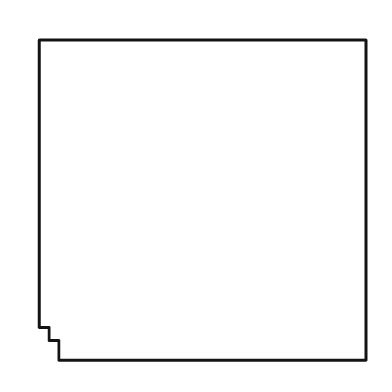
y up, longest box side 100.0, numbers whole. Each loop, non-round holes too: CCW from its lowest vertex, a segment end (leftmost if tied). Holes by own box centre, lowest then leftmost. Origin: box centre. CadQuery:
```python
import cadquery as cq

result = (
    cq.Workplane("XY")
    .moveTo(-44.0, -49.0)
    .lineTo(50.0, -49.0)
    .lineTo(50.0, 49.0)
    .lineTo(-50.0, 49.0)
    .lineTo(-50.0, -39.0)
    .lineTo(-47.0, -39.0)
    .lineTo(-47.0, -43.0)
    .lineTo(-44.0, -43.0)
    .close()
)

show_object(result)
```